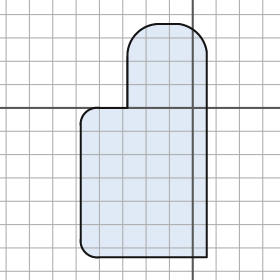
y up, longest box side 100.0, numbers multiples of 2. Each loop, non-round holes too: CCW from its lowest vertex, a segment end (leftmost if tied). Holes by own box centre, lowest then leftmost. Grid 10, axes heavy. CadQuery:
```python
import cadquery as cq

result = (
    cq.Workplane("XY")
    .moveTo(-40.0, -64.0)
    .lineTo(6.0, -64.0)
    .lineTo(6.0, 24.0)
    .threePointArc((2.0, 32.0), (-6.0, 36.0))
    .lineTo(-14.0, 36.0)
    .threePointArc((-24.0, 32.0), (-28.0, 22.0))
    .lineTo(-28.0, 0.0)
    .lineTo(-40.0, 0.0)
    .threePointArc((-46.0, -2.0), (-48.0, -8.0))
    .lineTo(-48.0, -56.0)
    .threePointArc((-46.0, -62.0), (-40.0, -64.0))
    .close()
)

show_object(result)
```